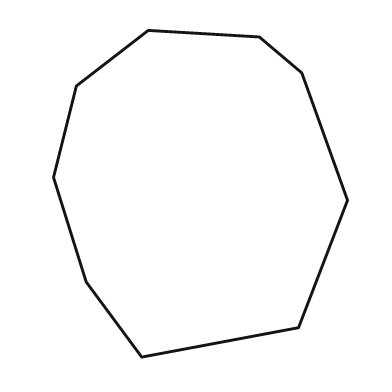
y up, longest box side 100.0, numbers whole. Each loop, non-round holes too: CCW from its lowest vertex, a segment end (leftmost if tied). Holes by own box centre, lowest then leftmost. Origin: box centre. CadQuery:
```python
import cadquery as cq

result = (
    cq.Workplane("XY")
    .moveTo(-18.0, -50.0)
    .lineTo(30.0, -41.0)
    .lineTo(45.0, -2.0)
    .lineTo(31.0, 37.0)
    .lineTo(18.0, 48.0)
    .lineTo(-16.0, 50.0)
    .lineTo(-38.0, 33.0)
    .lineTo(-45.0, 5.0)
    .lineTo(-35.0, -27.0)
    .close()
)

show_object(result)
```